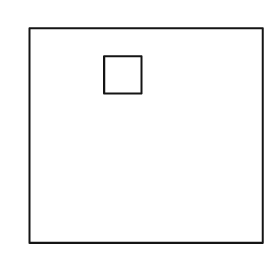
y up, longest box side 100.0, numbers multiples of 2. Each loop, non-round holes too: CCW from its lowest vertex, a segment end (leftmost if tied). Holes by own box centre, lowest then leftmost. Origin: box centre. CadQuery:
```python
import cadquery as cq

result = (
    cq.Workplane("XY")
    .moveTo(-50.0, -46.0)
    .lineTo(50.0, -46.0)
    .lineTo(50.0, 46.0)
    .lineTo(-50.0, 46.0)
    .close()
    .moveTo(-18.0, 18.0)
    .lineTo(-2.0, 18.0)
    .lineTo(-2.0, 34.0)
    .lineTo(-18.0, 34.0)
    .close()
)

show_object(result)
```